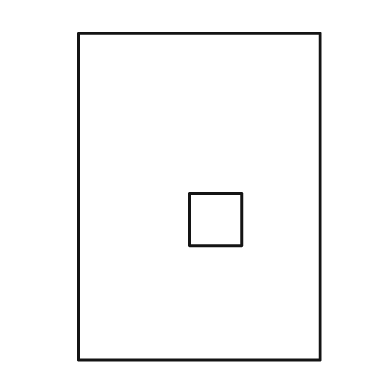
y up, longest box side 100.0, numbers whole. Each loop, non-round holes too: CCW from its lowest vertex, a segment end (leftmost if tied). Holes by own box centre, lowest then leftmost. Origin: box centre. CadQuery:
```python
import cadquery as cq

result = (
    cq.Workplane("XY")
    .moveTo(-37.0, -50.0)
    .lineTo(37.0, -50.0)
    .lineTo(37.0, 50.0)
    .lineTo(-37.0, 50.0)
    .close()
    .moveTo(-3.0, -15.0)
    .lineTo(13.0, -15.0)
    .lineTo(13.0, 1.0)
    .lineTo(-3.0, 1.0)
    .close()
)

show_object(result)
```